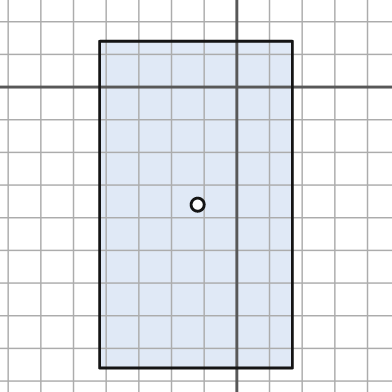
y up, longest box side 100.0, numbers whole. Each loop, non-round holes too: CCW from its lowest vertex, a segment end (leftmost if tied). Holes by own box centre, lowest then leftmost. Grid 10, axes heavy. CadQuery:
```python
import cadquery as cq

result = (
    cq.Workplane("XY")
    .moveTo(-42.0, -86.0)
    .lineTo(17.0, -86.0)
    .lineTo(17.0, 14.0)
    .lineTo(-42.0, 14.0)
    .close()
    .moveTo(-12.0, -36.0)
    .circle(2.0)
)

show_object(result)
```